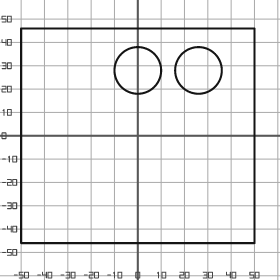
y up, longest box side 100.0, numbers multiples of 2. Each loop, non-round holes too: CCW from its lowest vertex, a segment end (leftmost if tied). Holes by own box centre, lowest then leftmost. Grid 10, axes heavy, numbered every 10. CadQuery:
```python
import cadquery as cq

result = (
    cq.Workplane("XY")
    .moveTo(-50.0, -46.0)
    .lineTo(50.0, -46.0)
    .lineTo(50.0, 46.0)
    .lineTo(-50.0, 46.0)
    .close()
    .moveTo(0.0, 28.0)
    .circle(10.0)
    .moveTo(26.0, 28.0)
    .circle(10.0)
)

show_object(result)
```